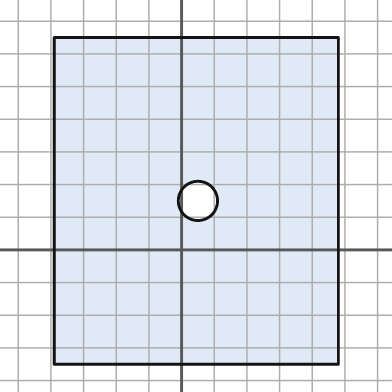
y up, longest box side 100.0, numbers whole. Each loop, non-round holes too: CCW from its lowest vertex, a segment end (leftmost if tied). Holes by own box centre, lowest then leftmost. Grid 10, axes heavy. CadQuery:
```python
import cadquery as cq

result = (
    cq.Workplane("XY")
    .moveTo(-39.0, -35.0)
    .lineTo(48.0, -35.0)
    .lineTo(48.0, 65.0)
    .lineTo(-39.0, 65.0)
    .close()
    .moveTo(5.0, 15.0)
    .circle(6.0)
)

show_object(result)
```